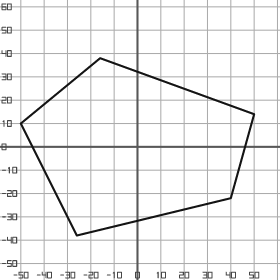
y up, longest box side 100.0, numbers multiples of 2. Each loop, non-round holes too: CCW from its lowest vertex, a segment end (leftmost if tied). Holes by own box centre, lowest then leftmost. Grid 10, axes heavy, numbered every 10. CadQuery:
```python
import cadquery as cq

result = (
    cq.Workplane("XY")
    .moveTo(-26.0, -38.0)
    .lineTo(40.0, -22.0)
    .lineTo(50.0, 14.0)
    .lineTo(-16.0, 38.0)
    .lineTo(-50.0, 10.0)
    .close()
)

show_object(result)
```